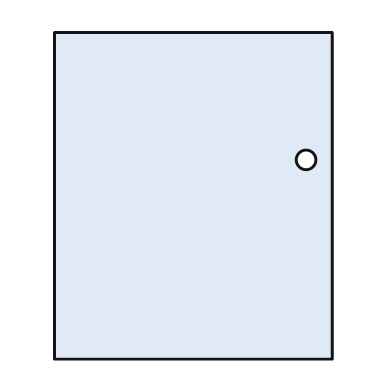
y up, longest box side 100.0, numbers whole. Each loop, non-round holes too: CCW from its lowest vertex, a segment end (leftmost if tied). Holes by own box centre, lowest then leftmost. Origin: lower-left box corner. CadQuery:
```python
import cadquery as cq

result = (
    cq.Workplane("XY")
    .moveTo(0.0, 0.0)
    .lineTo(85.0, 0.0)
    .lineTo(85.0, 100.0)
    .lineTo(0.0, 100.0)
    .close()
    .moveTo(77.0, 61.0)
    .circle(3.0)
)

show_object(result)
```